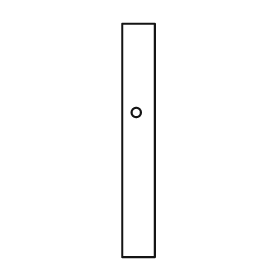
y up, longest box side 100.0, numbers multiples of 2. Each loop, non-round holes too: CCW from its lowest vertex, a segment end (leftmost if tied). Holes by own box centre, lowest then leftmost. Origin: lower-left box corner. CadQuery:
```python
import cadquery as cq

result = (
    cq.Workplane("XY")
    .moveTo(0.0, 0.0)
    .lineTo(14.0, 0.0)
    .lineTo(14.0, 100.0)
    .lineTo(0.0, 100.0)
    .close()
    .moveTo(6.0, 62.0)
    .circle(2.0)
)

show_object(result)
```